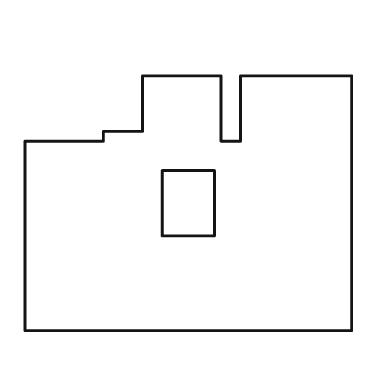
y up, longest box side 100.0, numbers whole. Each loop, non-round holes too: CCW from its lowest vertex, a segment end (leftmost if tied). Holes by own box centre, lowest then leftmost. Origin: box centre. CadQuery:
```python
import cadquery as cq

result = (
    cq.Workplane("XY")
    .moveTo(-50.0, -39.0)
    .lineTo(50.0, -39.0)
    .lineTo(50.0, 39.0)
    .lineTo(16.0, 39.0)
    .lineTo(16.0, 19.0)
    .lineTo(10.0, 19.0)
    .lineTo(10.0, 39.0)
    .lineTo(-14.0, 39.0)
    .lineTo(-14.0, 22.0)
    .lineTo(-26.0, 22.0)
    .lineTo(-26.0, 19.0)
    .lineTo(-50.0, 19.0)
    .close()
    .moveTo(-8.0, -10.0)
    .lineTo(8.0, -10.0)
    .lineTo(8.0, 10.0)
    .lineTo(-8.0, 10.0)
    .close()
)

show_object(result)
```